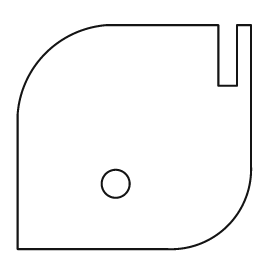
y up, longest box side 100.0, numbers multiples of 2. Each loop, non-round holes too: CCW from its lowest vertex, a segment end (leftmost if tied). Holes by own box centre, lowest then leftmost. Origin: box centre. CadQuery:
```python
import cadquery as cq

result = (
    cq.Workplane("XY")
    .moveTo(-50.0, -48.0)
    .lineTo(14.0, -48.0)
    .threePointArc((40.0, -38.0), (50.0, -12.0))
    .lineTo(50.0, 48.0)
    .lineTo(44.0, 48.0)
    .lineTo(44.0, 22.0)
    .lineTo(36.0, 22.0)
    .lineTo(36.0, 48.0)
    .lineTo(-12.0, 48.0)
    .threePointArc((-38.0, 36.0), (-50.0, 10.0))
    .close()
    .moveTo(-8.0, -20.0)
    .circle(6.0)
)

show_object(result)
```